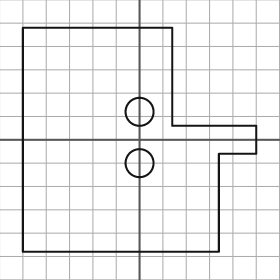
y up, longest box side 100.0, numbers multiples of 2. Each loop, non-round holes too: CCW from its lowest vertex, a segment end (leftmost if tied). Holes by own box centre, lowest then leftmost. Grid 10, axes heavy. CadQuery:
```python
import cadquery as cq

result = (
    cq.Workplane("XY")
    .moveTo(-50.0, -48.0)
    .lineTo(34.0, -48.0)
    .lineTo(34.0, -6.0)
    .lineTo(50.0, -6.0)
    .lineTo(50.0, 6.0)
    .lineTo(14.0, 6.0)
    .lineTo(14.0, 48.0)
    .lineTo(-50.0, 48.0)
    .close()
    .moveTo(0.0, -10.0)
    .circle(6.0)
    .moveTo(0.0, 12.0)
    .circle(6.0)
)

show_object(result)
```